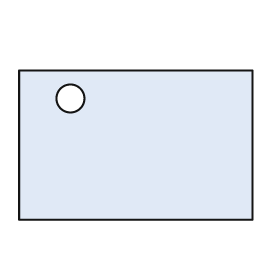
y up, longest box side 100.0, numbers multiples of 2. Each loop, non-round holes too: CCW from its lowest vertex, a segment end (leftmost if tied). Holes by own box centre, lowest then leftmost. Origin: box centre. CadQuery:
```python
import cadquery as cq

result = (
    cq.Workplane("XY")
    .moveTo(-50.0, -32.0)
    .lineTo(50.0, -32.0)
    .lineTo(50.0, 32.0)
    .lineTo(-50.0, 32.0)
    .close()
    .moveTo(-28.0, 20.0)
    .circle(6.0)
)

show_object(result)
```